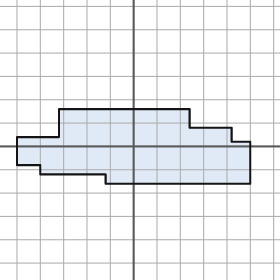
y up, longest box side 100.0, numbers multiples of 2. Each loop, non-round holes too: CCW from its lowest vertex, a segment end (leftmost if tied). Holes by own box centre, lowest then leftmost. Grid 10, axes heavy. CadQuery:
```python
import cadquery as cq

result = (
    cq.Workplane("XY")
    .moveTo(-12.0, -16.0)
    .lineTo(50.0, -16.0)
    .lineTo(50.0, 2.0)
    .lineTo(42.0, 2.0)
    .lineTo(42.0, 8.0)
    .lineTo(24.0, 8.0)
    .lineTo(24.0, 16.0)
    .lineTo(-32.0, 16.0)
    .lineTo(-32.0, 4.0)
    .lineTo(-50.0, 4.0)
    .lineTo(-50.0, -8.0)
    .lineTo(-40.0, -8.0)
    .lineTo(-40.0, -12.0)
    .lineTo(-12.0, -12.0)
    .close()
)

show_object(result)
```